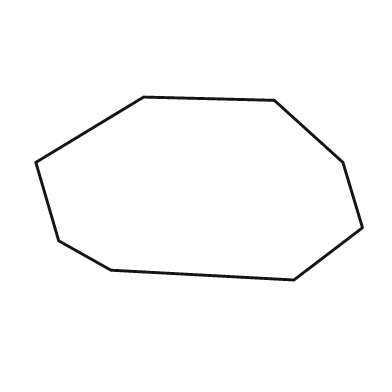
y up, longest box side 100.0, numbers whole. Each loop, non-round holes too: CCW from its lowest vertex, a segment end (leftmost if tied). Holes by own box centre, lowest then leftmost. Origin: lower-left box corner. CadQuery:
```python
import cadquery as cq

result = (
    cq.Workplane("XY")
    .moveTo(79.0, 0.0)
    .lineTo(100.0, 16.0)
    .lineTo(94.0, 36.0)
    .lineTo(73.0, 55.0)
    .lineTo(33.0, 56.0)
    .lineTo(0.0, 36.0)
    .lineTo(7.0, 12.0)
    .lineTo(23.0, 3.0)
    .close()
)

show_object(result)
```